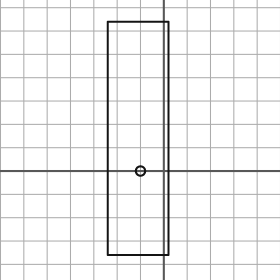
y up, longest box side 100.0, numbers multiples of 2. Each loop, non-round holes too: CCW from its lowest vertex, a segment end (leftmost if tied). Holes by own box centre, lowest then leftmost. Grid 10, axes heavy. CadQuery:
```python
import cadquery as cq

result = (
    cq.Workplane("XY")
    .moveTo(-24.0, -36.0)
    .lineTo(2.0, -36.0)
    .lineTo(2.0, 64.0)
    .lineTo(-24.0, 64.0)
    .close()
    .moveTo(-10.0, 0.0)
    .circle(2.0)
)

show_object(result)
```